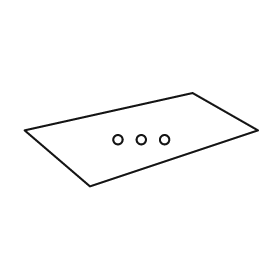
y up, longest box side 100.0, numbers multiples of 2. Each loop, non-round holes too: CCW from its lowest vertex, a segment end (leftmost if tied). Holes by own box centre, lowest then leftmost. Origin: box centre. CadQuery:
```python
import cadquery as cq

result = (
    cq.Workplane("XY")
    .moveTo(-22.0, -20.0)
    .lineTo(50.0, 4.0)
    .lineTo(22.0, 20.0)
    .lineTo(-50.0, 4.0)
    .close()
    .moveTo(-10.0, 0.0)
    .circle(2.0)
    .moveTo(0.0, 0.0)
    .circle(2.0)
    .moveTo(10.0, 0.0)
    .circle(2.0)
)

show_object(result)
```